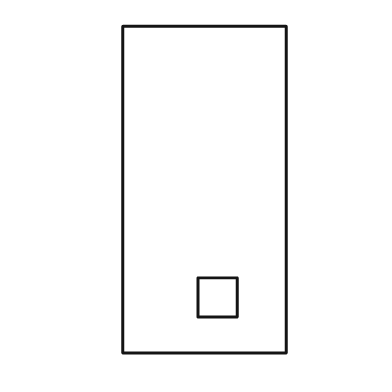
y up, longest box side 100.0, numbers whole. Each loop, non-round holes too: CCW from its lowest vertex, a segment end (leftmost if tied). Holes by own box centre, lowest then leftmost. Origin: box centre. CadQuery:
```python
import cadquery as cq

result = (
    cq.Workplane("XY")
    .moveTo(-25.0, -50.0)
    .lineTo(25.0, -50.0)
    .lineTo(25.0, 50.0)
    .lineTo(-25.0, 50.0)
    .close()
    .moveTo(-2.0, -39.0)
    .lineTo(10.0, -39.0)
    .lineTo(10.0, -27.0)
    .lineTo(-2.0, -27.0)
    .close()
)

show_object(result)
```